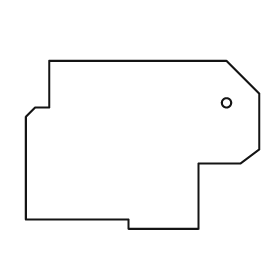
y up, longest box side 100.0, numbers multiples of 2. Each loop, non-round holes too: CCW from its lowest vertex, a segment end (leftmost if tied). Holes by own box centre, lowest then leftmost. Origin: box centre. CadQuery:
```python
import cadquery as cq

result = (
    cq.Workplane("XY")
    .moveTo(-6.0, -36.0)
    .lineTo(24.0, -36.0)
    .lineTo(24.0, -8.0)
    .lineTo(42.0, -8.0)
    .lineTo(50.0, -2.0)
    .lineTo(50.0, 22.0)
    .lineTo(36.0, 36.0)
    .lineTo(-40.0, 36.0)
    .lineTo(-40.0, 16.0)
    .lineTo(-46.0, 16.0)
    .lineTo(-50.0, 12.0)
    .lineTo(-50.0, -32.0)
    .lineTo(-6.0, -32.0)
    .close()
    .moveTo(36.0, 18.0)
    .circle(2.0)
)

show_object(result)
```